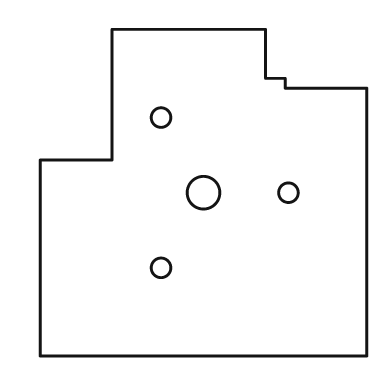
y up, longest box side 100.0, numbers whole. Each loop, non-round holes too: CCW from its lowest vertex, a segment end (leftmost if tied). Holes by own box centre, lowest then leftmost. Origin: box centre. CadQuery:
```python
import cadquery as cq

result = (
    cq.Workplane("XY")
    .moveTo(-50.0, -50.0)
    .lineTo(50.0, -50.0)
    .lineTo(50.0, 32.0)
    .lineTo(25.0, 32.0)
    .lineTo(25.0, 35.0)
    .lineTo(19.0, 35.0)
    .lineTo(19.0, 50.0)
    .lineTo(-28.0, 50.0)
    .lineTo(-28.0, 10.0)
    .lineTo(-50.0, 10.0)
    .close()
    .moveTo(-13.0, -23.0)
    .circle(3.0)
    .moveTo(0.0, 0.0)
    .circle(5.0)
    .moveTo(26.0, 0.0)
    .circle(3.0)
    .moveTo(-13.0, 23.0)
    .circle(3.0)
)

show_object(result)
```